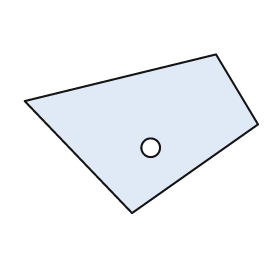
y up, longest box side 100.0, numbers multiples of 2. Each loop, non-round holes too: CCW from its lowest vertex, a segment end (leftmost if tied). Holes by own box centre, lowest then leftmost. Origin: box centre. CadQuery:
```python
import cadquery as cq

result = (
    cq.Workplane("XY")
    .moveTo(-4.0, -34.0)
    .lineTo(50.0, 4.0)
    .lineTo(32.0, 34.0)
    .lineTo(-50.0, 14.0)
    .close()
    .moveTo(4.0, -6.0)
    .circle(4.0)
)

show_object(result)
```